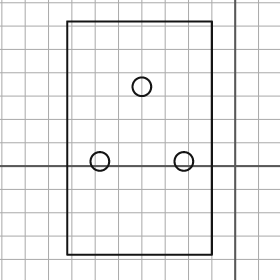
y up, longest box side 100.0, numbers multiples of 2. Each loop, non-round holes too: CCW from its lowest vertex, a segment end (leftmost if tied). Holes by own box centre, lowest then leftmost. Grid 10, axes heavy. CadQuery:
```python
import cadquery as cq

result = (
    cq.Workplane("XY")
    .moveTo(-72.0, -38.0)
    .lineTo(-10.0, -38.0)
    .lineTo(-10.0, 62.0)
    .lineTo(-72.0, 62.0)
    .close()
    .moveTo(-58.0, 2.0)
    .circle(4.0)
    .moveTo(-22.0, 2.0)
    .circle(4.0)
    .moveTo(-40.0, 34.0)
    .circle(4.0)
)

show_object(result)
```